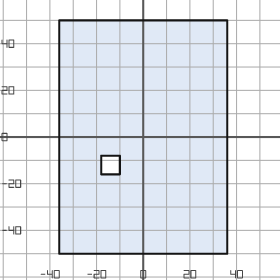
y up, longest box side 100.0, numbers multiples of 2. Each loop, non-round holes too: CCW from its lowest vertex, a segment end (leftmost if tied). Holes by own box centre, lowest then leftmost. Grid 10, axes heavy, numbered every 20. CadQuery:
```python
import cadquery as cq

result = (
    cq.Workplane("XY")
    .moveTo(-36.0, -50.0)
    .lineTo(36.0, -50.0)
    .lineTo(36.0, 50.0)
    .lineTo(-36.0, 50.0)
    .close()
    .moveTo(-18.0, -16.0)
    .lineTo(-10.0, -16.0)
    .lineTo(-10.0, -8.0)
    .lineTo(-18.0, -8.0)
    .close()
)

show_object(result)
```